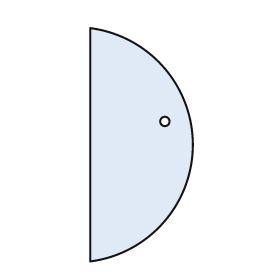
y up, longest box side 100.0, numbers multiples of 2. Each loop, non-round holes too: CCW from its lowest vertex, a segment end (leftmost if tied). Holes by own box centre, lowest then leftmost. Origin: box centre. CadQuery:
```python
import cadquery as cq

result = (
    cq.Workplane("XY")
    .moveTo(-22.0, -50.0)
    .threePointArc((22.0, 0.0), (-22.0, 50.0))
    .close()
    .moveTo(10.0, 10.0)
    .circle(2.0)
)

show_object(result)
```